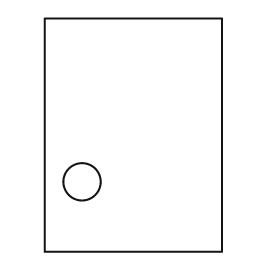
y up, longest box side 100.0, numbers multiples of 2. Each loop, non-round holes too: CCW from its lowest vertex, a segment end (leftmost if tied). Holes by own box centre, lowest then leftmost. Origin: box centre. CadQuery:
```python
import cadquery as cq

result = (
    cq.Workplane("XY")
    .moveTo(-38.0, -50.0)
    .lineTo(38.0, -50.0)
    .lineTo(38.0, 50.0)
    .lineTo(-38.0, 50.0)
    .close()
    .moveTo(-22.0, -20.0)
    .circle(8.0)
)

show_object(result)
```